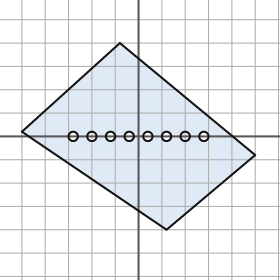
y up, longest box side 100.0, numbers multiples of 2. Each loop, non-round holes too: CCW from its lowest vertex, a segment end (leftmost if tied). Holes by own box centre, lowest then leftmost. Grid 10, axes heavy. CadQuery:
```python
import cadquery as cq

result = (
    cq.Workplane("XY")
    .moveTo(12.0, -40.0)
    .lineTo(50.0, -8.0)
    .lineTo(-8.0, 40.0)
    .lineTo(-50.0, 2.0)
    .close()
    .moveTo(-28.0, 0.0)
    .circle(2.0)
    .moveTo(-20.0, 0.0)
    .circle(2.0)
    .moveTo(-12.0, 0.0)
    .circle(2.0)
    .moveTo(-4.0, 0.0)
    .circle(2.0)
    .moveTo(4.0, 0.0)
    .circle(2.0)
    .moveTo(12.0, 0.0)
    .circle(2.0)
    .moveTo(20.0, 0.0)
    .circle(2.0)
    .moveTo(28.0, 0.0)
    .circle(2.0)
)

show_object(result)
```